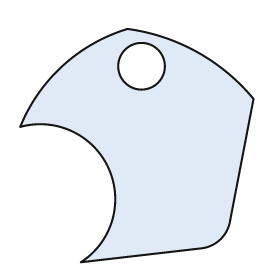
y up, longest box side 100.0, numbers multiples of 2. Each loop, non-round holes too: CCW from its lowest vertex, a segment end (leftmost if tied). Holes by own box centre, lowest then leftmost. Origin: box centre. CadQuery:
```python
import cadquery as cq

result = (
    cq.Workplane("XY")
    .moveTo(-24.0, -50.0)
    .lineTo(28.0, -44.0)
    .threePointArc((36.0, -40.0), (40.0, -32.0))
    .lineTo(50.0, 20.0)
    .threePointArc((26.0, 40.0), (-4.0, 50.0))
    .threePointArc((-32.0, 34.0), (-50.0, 8.0))
    .threePointArc((-12.0, -10.0), (-24.0, -50.0))
    .close()
    .moveTo(2.0, 34.0)
    .circle(10.0)
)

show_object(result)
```